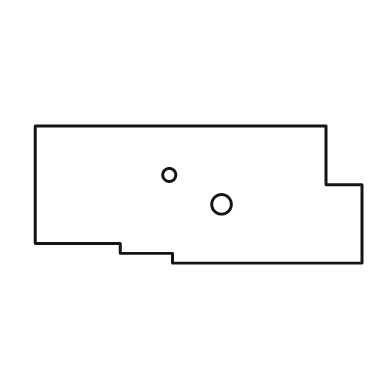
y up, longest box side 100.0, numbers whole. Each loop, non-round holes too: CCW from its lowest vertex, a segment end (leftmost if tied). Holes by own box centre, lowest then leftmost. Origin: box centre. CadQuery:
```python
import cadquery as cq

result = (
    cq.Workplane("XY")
    .moveTo(-8.0, -21.0)
    .lineTo(50.0, -21.0)
    .lineTo(50.0, 3.0)
    .lineTo(39.0, 3.0)
    .lineTo(39.0, 21.0)
    .lineTo(-50.0, 21.0)
    .lineTo(-50.0, -15.0)
    .lineTo(-24.0, -15.0)
    .lineTo(-24.0, -18.0)
    .lineTo(-8.0, -18.0)
    .close()
    .moveTo(7.0, -3.0)
    .circle(3.0)
    .moveTo(-9.0, 6.0)
    .circle(2.0)
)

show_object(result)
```